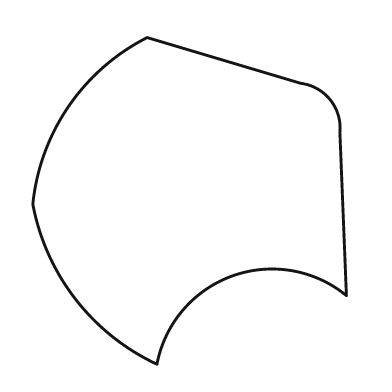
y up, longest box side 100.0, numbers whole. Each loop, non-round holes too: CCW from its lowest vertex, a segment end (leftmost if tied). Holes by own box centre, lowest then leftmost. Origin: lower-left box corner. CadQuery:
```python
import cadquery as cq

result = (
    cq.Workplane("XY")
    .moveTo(38.0, 0.0)
    .threePointArc((61.0, 27.0), (96.0, 21.0))
    .lineTo(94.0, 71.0)
    .threePointArc((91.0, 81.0), (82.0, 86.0))
    .lineTo(35.0, 100.0)
    .threePointArc((11.0, 79.0), (0.0, 49.0))
    .threePointArc((13.0, 20.0), (38.0, 0.0))
    .close()
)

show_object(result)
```